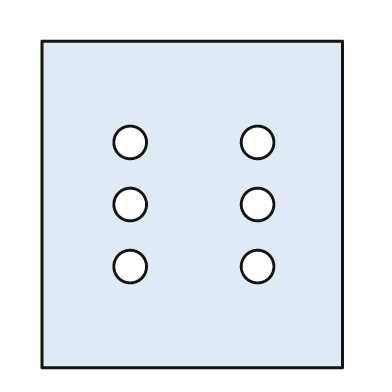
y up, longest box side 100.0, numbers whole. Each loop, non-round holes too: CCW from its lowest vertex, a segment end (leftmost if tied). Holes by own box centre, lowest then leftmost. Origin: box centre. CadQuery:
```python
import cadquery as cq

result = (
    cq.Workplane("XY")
    .moveTo(-46.0, -50.0)
    .lineTo(46.0, -50.0)
    .lineTo(46.0, 50.0)
    .lineTo(-46.0, 50.0)
    .close()
    .moveTo(-19.0, -19.0)
    .circle(5.0)
    .moveTo(20.0, -19.0)
    .circle(5.0)
    .moveTo(-19.0, 0.0)
    .circle(5.0)
    .moveTo(20.0, 0.0)
    .circle(5.0)
    .moveTo(-19.0, 19.0)
    .circle(5.0)
    .moveTo(20.0, 19.0)
    .circle(5.0)
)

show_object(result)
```